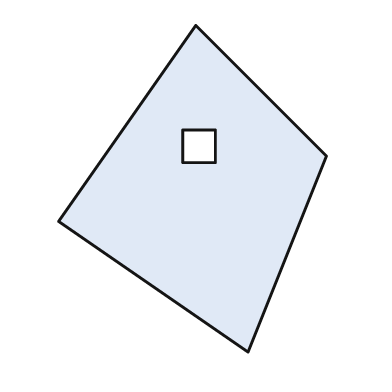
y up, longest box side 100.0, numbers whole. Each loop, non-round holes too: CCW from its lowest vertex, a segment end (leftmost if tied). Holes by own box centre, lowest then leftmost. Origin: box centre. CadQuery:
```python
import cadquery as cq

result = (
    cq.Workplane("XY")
    .moveTo(17.0, -50.0)
    .lineTo(41.0, 10.0)
    .lineTo(1.0, 50.0)
    .lineTo(-41.0, -10.0)
    .close()
    .moveTo(-3.0, 8.0)
    .lineTo(7.0, 8.0)
    .lineTo(7.0, 18.0)
    .lineTo(-3.0, 18.0)
    .close()
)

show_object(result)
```